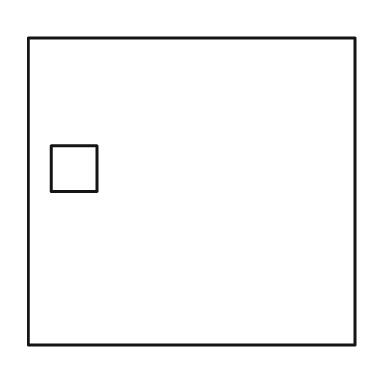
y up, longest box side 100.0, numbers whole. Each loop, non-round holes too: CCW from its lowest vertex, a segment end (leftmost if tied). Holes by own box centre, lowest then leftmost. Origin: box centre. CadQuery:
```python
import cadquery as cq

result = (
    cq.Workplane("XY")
    .moveTo(-50.0, -47.0)
    .lineTo(50.0, -47.0)
    .lineTo(50.0, 47.0)
    .lineTo(-50.0, 47.0)
    .close()
    .moveTo(-43.0, 0.0)
    .lineTo(-29.0, 0.0)
    .lineTo(-29.0, 14.0)
    .lineTo(-43.0, 14.0)
    .close()
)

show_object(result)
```